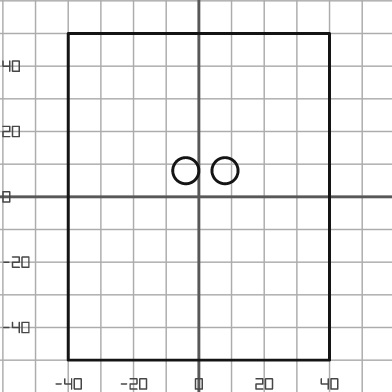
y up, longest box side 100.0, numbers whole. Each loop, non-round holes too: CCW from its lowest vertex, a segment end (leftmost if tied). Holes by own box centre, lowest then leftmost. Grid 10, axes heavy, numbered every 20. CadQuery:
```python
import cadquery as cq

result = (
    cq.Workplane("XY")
    .moveTo(-40.0, -50.0)
    .lineTo(40.0, -50.0)
    .lineTo(40.0, 50.0)
    .lineTo(-40.0, 50.0)
    .close()
    .moveTo(-4.0, 8.0)
    .circle(4.0)
    .moveTo(8.0, 8.0)
    .circle(4.0)
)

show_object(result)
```